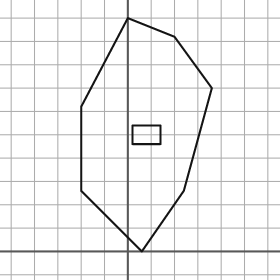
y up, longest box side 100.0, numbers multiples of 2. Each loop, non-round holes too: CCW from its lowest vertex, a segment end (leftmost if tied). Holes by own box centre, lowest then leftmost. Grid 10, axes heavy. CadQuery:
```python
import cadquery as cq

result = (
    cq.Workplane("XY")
    .moveTo(6.0, 0.0)
    .lineTo(24.0, 26.0)
    .lineTo(36.0, 70.0)
    .lineTo(20.0, 92.0)
    .lineTo(0.0, 100.0)
    .lineTo(-20.0, 62.0)
    .lineTo(-20.0, 26.0)
    .close()
    .moveTo(2.0, 46.0)
    .lineTo(14.0, 46.0)
    .lineTo(14.0, 54.0)
    .lineTo(2.0, 54.0)
    .close()
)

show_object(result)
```